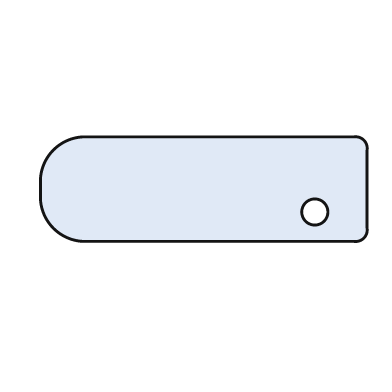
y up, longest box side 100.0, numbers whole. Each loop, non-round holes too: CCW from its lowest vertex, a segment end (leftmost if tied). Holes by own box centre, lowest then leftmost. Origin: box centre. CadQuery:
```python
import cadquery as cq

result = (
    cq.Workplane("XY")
    .moveTo(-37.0, -16.0)
    .lineTo(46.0, -16.0)
    .threePointArc((49.0, -15.0), (50.0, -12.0))
    .lineTo(50.0, 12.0)
    .threePointArc((49.0, 15.0), (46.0, 16.0))
    .lineTo(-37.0, 16.0)
    .threePointArc((-46.0, 12.0), (-50.0, 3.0))
    .lineTo(-50.0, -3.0)
    .threePointArc((-46.0, -12.0), (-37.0, -16.0))
    .close()
    .moveTo(34.0, -7.0)
    .circle(4.0)
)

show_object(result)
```